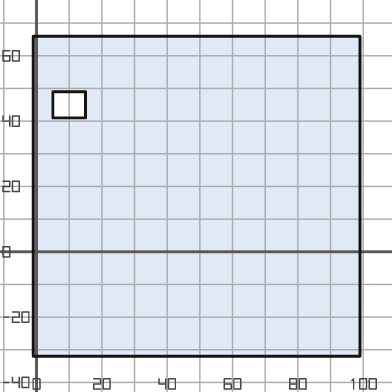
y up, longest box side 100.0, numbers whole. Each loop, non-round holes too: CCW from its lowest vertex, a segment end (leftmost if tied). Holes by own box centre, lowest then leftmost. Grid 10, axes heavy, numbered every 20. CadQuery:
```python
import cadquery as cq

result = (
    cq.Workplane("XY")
    .moveTo(-1.0, -32.0)
    .lineTo(99.0, -32.0)
    .lineTo(99.0, 66.0)
    .lineTo(-1.0, 66.0)
    .close()
    .moveTo(5.0, 41.0)
    .lineTo(15.0, 41.0)
    .lineTo(15.0, 49.0)
    .lineTo(5.0, 49.0)
    .close()
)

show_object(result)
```